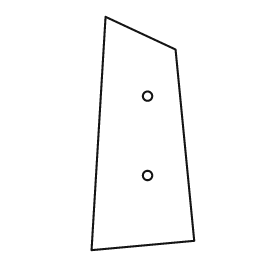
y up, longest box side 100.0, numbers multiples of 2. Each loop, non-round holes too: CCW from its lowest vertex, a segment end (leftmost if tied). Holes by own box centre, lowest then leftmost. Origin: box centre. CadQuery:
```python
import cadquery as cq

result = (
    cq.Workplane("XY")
    .moveTo(-22.0, -50.0)
    .lineTo(22.0, -46.0)
    .lineTo(14.0, 36.0)
    .lineTo(-16.0, 50.0)
    .close()
    .moveTo(2.0, -18.0)
    .circle(2.0)
    .moveTo(2.0, 16.0)
    .circle(2.0)
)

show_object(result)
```